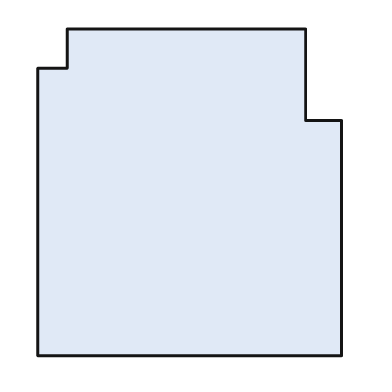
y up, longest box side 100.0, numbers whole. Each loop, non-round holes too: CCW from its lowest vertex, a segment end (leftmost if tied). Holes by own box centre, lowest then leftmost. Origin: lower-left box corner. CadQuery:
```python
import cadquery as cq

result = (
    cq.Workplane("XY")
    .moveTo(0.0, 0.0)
    .lineTo(93.0, 0.0)
    .lineTo(93.0, 72.0)
    .lineTo(82.0, 72.0)
    .lineTo(82.0, 100.0)
    .lineTo(9.0, 100.0)
    .lineTo(9.0, 88.0)
    .lineTo(0.0, 88.0)
    .close()
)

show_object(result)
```